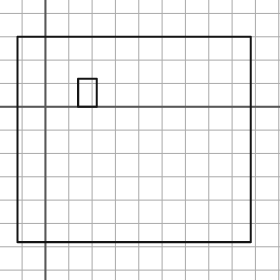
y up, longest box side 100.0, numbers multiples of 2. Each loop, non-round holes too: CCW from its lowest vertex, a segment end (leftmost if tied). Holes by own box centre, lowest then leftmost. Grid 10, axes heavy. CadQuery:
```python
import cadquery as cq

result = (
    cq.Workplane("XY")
    .moveTo(-12.0, -58.0)
    .lineTo(88.0, -58.0)
    .lineTo(88.0, 30.0)
    .lineTo(-12.0, 30.0)
    .close()
    .moveTo(14.0, 0.0)
    .lineTo(22.0, 0.0)
    .lineTo(22.0, 12.0)
    .lineTo(14.0, 12.0)
    .close()
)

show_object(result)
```